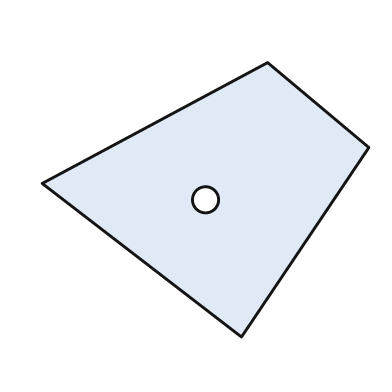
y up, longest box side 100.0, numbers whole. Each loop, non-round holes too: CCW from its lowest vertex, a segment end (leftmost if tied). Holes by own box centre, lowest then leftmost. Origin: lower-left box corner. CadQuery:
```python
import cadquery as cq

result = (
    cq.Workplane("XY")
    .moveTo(61.0, 0.0)
    .lineTo(100.0, 58.0)
    .lineTo(69.0, 84.0)
    .lineTo(0.0, 47.0)
    .close()
    .moveTo(50.0, 42.0)
    .circle(4.0)
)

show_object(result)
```